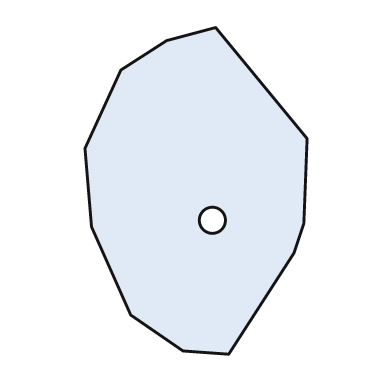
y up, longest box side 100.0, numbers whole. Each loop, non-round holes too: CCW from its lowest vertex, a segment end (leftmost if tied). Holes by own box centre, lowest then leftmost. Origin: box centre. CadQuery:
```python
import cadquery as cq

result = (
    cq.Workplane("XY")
    .moveTo(10.0, -50.0)
    .lineTo(30.0, -19.0)
    .lineTo(33.0, -10.0)
    .lineTo(34.0, 16.0)
    .lineTo(6.0, 50.0)
    .lineTo(-9.0, 46.0)
    .lineTo(-23.0, 37.0)
    .lineTo(-34.0, 13.0)
    .lineTo(-32.0, -11.0)
    .lineTo(-20.0, -38.0)
    .lineTo(-4.0, -49.0)
    .close()
    .moveTo(5.0, -9.0)
    .circle(4.0)
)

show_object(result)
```